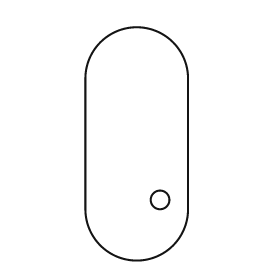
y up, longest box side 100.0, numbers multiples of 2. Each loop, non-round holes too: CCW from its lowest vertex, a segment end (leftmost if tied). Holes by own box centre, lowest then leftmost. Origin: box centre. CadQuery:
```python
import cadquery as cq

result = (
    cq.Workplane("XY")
    .moveTo(-22.0, -28.0)
    .threePointArc((0.0, -50.0), (22.0, -28.0))
    .lineTo(22.0, 28.0)
    .threePointArc((0.0, 50.0), (-22.0, 28.0))
    .close()
    .moveTo(10.0, -24.0)
    .circle(4.0)
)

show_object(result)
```